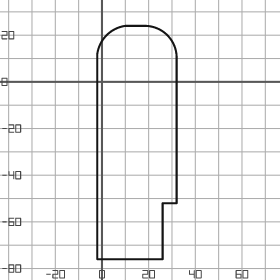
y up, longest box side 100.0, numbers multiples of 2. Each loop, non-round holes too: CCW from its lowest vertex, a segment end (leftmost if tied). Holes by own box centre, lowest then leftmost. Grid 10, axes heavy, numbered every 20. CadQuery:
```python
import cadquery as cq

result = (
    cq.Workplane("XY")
    .moveTo(-2.0, -76.0)
    .lineTo(26.0, -76.0)
    .lineTo(26.0, -52.0)
    .lineTo(32.0, -52.0)
    .lineTo(32.0, 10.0)
    .threePointArc((28.0, 20.0), (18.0, 24.0))
    .lineTo(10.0, 24.0)
    .threePointArc((2.0, 20.0), (-2.0, 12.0))
    .close()
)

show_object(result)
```